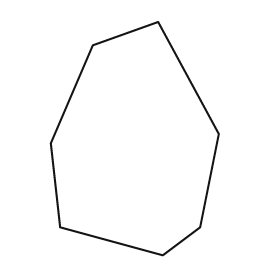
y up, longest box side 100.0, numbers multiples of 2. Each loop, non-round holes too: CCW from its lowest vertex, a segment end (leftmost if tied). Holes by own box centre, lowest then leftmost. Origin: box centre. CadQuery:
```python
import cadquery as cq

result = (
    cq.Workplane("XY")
    .moveTo(12.0, -50.0)
    .lineTo(28.0, -38.0)
    .lineTo(36.0, 2.0)
    .lineTo(10.0, 50.0)
    .lineTo(-18.0, 40.0)
    .lineTo(-36.0, -2.0)
    .lineTo(-32.0, -38.0)
    .close()
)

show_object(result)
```